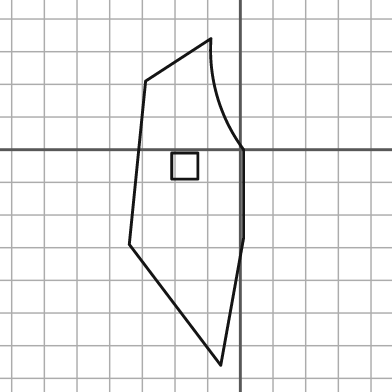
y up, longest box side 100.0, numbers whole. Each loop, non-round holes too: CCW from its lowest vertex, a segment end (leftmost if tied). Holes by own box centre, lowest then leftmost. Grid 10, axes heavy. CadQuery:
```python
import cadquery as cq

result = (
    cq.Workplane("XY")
    .moveTo(-6.0, -66.0)
    .lineTo(1.0, -27.0)
    .lineTo(1.0, 0.0)
    .threePointArc((-7.0, 16.0), (-9.0, 34.0))
    .lineTo(-29.0, 21.0)
    .lineTo(-34.0, -29.0)
    .close()
    .moveTo(-21.0, -9.0)
    .lineTo(-13.0, -9.0)
    .lineTo(-13.0, -1.0)
    .lineTo(-21.0, -1.0)
    .close()
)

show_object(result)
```